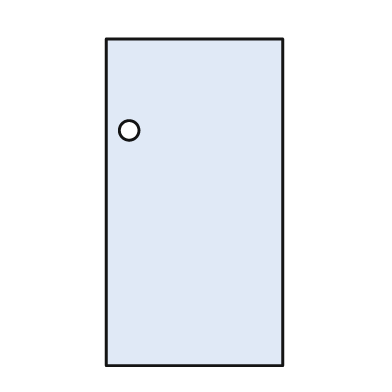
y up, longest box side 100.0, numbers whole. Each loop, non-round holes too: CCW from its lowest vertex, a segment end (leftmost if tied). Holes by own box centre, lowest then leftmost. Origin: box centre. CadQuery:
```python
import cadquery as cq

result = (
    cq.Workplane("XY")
    .moveTo(-27.0, -50.0)
    .lineTo(27.0, -50.0)
    .lineTo(27.0, 50.0)
    .lineTo(-27.0, 50.0)
    .close()
    .moveTo(-20.0, 22.0)
    .circle(3.0)
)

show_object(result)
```